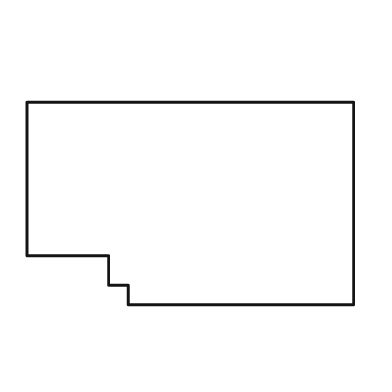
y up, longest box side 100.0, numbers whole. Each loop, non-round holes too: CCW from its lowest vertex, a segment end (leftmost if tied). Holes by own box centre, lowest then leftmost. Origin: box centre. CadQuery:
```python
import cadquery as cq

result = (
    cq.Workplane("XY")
    .moveTo(-19.0, -31.0)
    .lineTo(50.0, -31.0)
    .lineTo(50.0, 31.0)
    .lineTo(-50.0, 31.0)
    .lineTo(-50.0, -16.0)
    .lineTo(-25.0, -16.0)
    .lineTo(-25.0, -25.0)
    .lineTo(-19.0, -25.0)
    .close()
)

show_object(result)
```